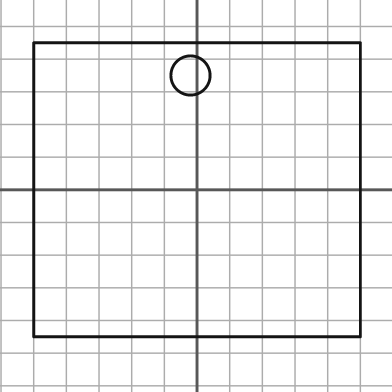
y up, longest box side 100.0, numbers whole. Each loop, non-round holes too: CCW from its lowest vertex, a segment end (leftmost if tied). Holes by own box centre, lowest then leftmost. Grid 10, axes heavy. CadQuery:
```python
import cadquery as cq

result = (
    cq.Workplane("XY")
    .moveTo(-50.0, -45.0)
    .lineTo(50.0, -45.0)
    .lineTo(50.0, 45.0)
    .lineTo(-50.0, 45.0)
    .close()
    .moveTo(-2.0, 35.0)
    .circle(6.0)
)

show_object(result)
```